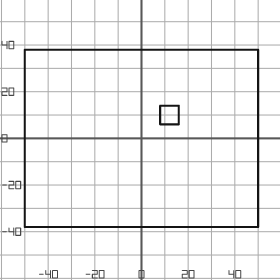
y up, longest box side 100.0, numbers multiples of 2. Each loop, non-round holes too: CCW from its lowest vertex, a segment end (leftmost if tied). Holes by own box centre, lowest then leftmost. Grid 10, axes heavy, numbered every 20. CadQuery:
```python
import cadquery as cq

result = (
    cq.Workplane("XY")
    .moveTo(-50.0, -38.0)
    .lineTo(50.0, -38.0)
    .lineTo(50.0, 38.0)
    .lineTo(-50.0, 38.0)
    .close()
    .moveTo(8.0, 6.0)
    .lineTo(16.0, 6.0)
    .lineTo(16.0, 14.0)
    .lineTo(8.0, 14.0)
    .close()
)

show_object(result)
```